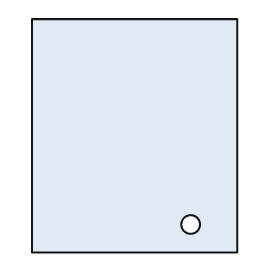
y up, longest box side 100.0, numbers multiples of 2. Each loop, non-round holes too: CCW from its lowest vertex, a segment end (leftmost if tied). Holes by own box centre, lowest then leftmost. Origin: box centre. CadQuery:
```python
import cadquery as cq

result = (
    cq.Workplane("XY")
    .moveTo(-44.0, -50.0)
    .lineTo(44.0, -50.0)
    .lineTo(44.0, 50.0)
    .lineTo(-44.0, 50.0)
    .close()
    .moveTo(24.0, -38.0)
    .circle(4.0)
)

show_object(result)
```